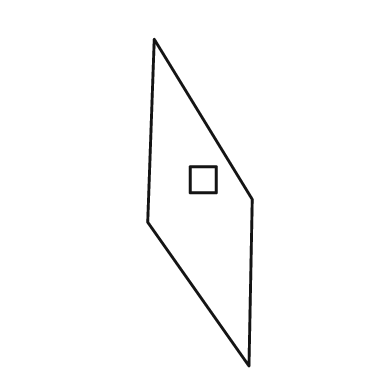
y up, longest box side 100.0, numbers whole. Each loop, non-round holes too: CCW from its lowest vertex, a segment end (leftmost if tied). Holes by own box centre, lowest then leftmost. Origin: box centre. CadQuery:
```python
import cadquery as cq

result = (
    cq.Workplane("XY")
    .moveTo(15.0, -50.0)
    .lineTo(16.0, 1.0)
    .lineTo(-14.0, 50.0)
    .lineTo(-16.0, -6.0)
    .close()
    .moveTo(-3.0, 3.0)
    .lineTo(5.0, 3.0)
    .lineTo(5.0, 11.0)
    .lineTo(-3.0, 11.0)
    .close()
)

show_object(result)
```